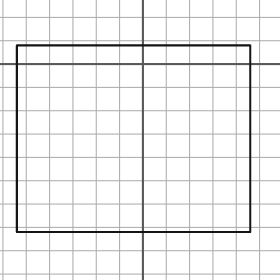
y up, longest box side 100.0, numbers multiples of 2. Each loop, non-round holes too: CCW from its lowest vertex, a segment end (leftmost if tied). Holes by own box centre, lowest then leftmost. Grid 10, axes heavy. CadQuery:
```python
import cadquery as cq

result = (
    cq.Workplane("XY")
    .moveTo(-54.0, -72.0)
    .lineTo(46.0, -72.0)
    .lineTo(46.0, 8.0)
    .lineTo(-54.0, 8.0)
    .close()
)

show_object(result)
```